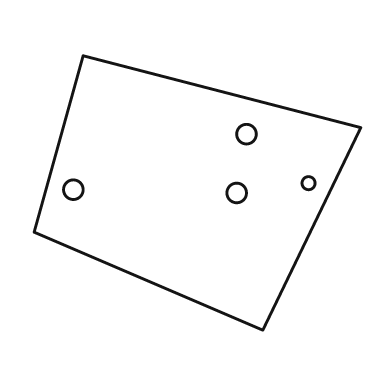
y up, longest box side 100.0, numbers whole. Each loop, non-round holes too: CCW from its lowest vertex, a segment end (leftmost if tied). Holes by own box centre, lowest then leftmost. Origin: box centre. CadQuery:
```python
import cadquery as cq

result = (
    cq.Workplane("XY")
    .moveTo(20.0, -42.0)
    .lineTo(50.0, 20.0)
    .lineTo(-35.0, 42.0)
    .lineTo(-50.0, -12.0)
    .close()
    .moveTo(12.0, 0.0)
    .circle(3.0)
    .moveTo(-38.0, 1.0)
    .circle(3.0)
    .moveTo(34.0, 3.0)
    .circle(2.0)
    .moveTo(15.0, 18.0)
    .circle(3.0)
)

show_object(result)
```